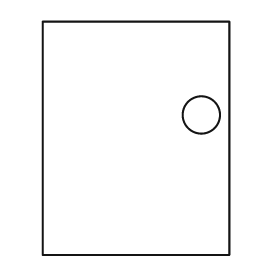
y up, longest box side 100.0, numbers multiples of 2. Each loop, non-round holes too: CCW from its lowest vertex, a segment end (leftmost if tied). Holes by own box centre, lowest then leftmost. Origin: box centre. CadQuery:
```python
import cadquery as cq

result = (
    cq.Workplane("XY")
    .moveTo(-40.0, -50.0)
    .lineTo(40.0, -50.0)
    .lineTo(40.0, 50.0)
    .lineTo(-40.0, 50.0)
    .close()
    .moveTo(28.0, 10.0)
    .circle(8.0)
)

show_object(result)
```